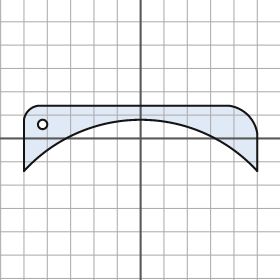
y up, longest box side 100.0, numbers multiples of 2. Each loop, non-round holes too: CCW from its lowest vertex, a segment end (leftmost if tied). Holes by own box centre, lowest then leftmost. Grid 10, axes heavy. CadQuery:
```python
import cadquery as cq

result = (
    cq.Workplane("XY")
    .moveTo(-50.0, -14.0)
    .threePointArc((0.0, 8.0), (50.0, -14.0))
    .lineTo(50.0, 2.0)
    .threePointArc((46.0, 10.0), (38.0, 14.0))
    .lineTo(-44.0, 14.0)
    .threePointArc((-48.0, 12.0), (-50.0, 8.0))
    .close()
    .moveTo(-42.0, 6.0)
    .circle(2.0)
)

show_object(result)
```